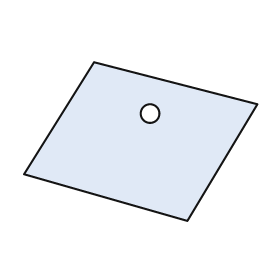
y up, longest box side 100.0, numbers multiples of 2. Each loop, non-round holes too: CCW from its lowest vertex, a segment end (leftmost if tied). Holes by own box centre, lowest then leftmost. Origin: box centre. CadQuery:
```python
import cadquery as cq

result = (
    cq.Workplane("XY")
    .moveTo(20.0, -34.0)
    .lineTo(50.0, 16.0)
    .lineTo(-20.0, 34.0)
    .lineTo(-50.0, -14.0)
    .close()
    .moveTo(4.0, 12.0)
    .circle(4.0)
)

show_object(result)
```